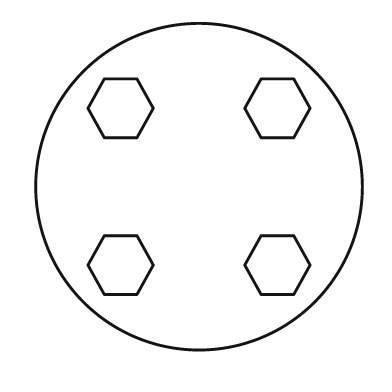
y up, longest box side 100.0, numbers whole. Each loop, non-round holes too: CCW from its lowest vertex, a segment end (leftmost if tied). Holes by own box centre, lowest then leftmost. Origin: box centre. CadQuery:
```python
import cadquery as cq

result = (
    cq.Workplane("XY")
    .moveTo(0.0, 0.0)
    .circle(50.0)
    .moveTo(-29.0, -33.0)
    .lineTo(-19.0, -33.0)
    .lineTo(-14.0, -24.0)
    .lineTo(-19.0, -15.0)
    .lineTo(-29.0, -15.0)
    .lineTo(-34.0, -24.0)
    .close()
    .moveTo(19.0, -33.0)
    .lineTo(29.0, -33.0)
    .lineTo(34.0, -24.0)
    .lineTo(29.0, -15.0)
    .lineTo(19.0, -15.0)
    .lineTo(14.0, -24.0)
    .close()
    .moveTo(-29.0, 15.0)
    .lineTo(-19.0, 15.0)
    .lineTo(-14.0, 24.0)
    .lineTo(-19.0, 33.0)
    .lineTo(-29.0, 33.0)
    .lineTo(-34.0, 24.0)
    .close()
    .moveTo(19.0, 15.0)
    .lineTo(29.0, 15.0)
    .lineTo(34.0, 24.0)
    .lineTo(29.0, 33.0)
    .lineTo(19.0, 33.0)
    .lineTo(14.0, 24.0)
    .close()
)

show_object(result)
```